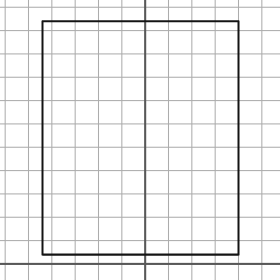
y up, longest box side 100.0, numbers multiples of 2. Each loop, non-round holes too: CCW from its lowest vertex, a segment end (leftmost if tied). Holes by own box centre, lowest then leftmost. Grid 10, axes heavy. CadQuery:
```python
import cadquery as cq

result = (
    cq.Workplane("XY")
    .moveTo(-44.0, 4.0)
    .lineTo(40.0, 4.0)
    .lineTo(40.0, 104.0)
    .lineTo(-44.0, 104.0)
    .close()
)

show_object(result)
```